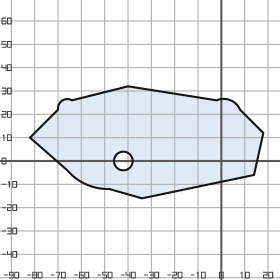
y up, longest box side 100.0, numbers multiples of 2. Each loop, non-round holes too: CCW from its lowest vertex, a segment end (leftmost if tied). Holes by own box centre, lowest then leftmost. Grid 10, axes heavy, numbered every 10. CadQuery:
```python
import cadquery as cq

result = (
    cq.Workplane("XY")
    .moveTo(-34.0, -16.0)
    .lineTo(14.0, -6.0)
    .lineTo(18.0, 12.0)
    .lineTo(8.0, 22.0)
    .threePointArc((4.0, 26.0), (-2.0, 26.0))
    .lineTo(-40.0, 32.0)
    .lineTo(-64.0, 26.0)
    .threePointArc((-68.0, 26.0), (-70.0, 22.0))
    .lineTo(-82.0, 10.0)
    .lineTo(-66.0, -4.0)
    .threePointArc((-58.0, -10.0), (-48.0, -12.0))
    .close()
    .moveTo(-42.0, 0.0)
    .circle(4.0)
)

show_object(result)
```